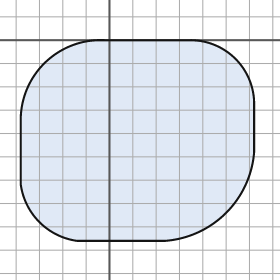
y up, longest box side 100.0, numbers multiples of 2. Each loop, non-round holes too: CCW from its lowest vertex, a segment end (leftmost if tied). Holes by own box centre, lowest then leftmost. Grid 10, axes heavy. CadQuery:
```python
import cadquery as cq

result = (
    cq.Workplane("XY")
    .moveTo(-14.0, -86.0)
    .lineTo(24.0, -86.0)
    .threePointArc((50.0, -74.0), (62.0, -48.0))
    .lineTo(62.0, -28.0)
    .threePointArc((54.0, -8.0), (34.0, 0.0))
    .lineTo(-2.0, 0.0)
    .threePointArc((-28.0, -10.0), (-38.0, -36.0))
    .lineTo(-38.0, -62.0)
    .threePointArc((-30.0, -78.0), (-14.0, -86.0))
    .close()
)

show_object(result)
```